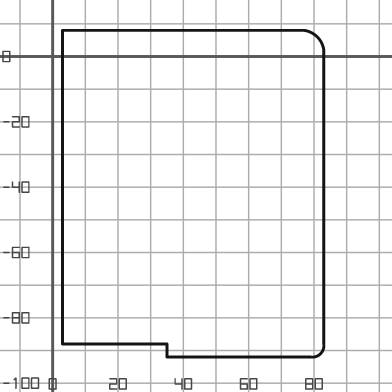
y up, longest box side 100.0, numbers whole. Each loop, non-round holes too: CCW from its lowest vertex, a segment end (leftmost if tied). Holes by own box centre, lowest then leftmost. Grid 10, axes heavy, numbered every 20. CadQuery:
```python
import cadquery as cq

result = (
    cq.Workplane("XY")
    .moveTo(35.0, -92.0)
    .lineTo(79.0, -92.0)
    .threePointArc((82.0, -91.0), (83.0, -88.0))
    .lineTo(83.0, 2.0)
    .threePointArc((81.0, 6.0), (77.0, 8.0))
    .lineTo(3.0, 8.0)
    .lineTo(3.0, -88.0)
    .lineTo(35.0, -88.0)
    .close()
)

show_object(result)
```